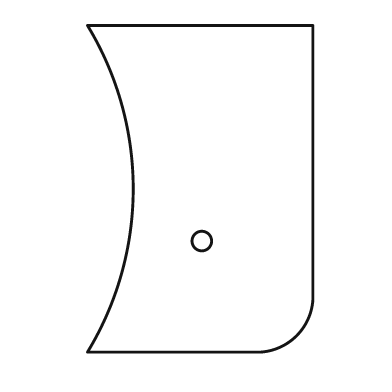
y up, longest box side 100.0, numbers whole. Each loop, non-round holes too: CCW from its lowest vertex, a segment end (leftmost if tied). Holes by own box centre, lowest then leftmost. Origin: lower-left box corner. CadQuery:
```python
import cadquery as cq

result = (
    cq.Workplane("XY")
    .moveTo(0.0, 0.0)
    .lineTo(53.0, 0.0)
    .threePointArc((64.0, 5.0), (69.0, 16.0))
    .lineTo(69.0, 100.0)
    .lineTo(0.0, 100.0)
    .threePointArc((14.0, 50.0), (0.0, 0.0))
    .close()
    .moveTo(35.0, 34.0)
    .circle(3.0)
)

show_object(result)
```